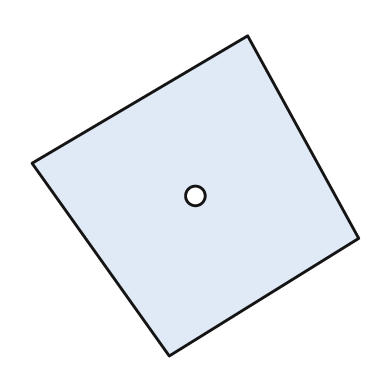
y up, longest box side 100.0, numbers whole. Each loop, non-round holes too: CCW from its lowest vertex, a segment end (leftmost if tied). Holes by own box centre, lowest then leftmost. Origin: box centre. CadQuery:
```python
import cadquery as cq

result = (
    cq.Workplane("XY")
    .moveTo(-8.0, -49.0)
    .lineTo(50.0, -13.0)
    .lineTo(16.0, 49.0)
    .lineTo(-50.0, 10.0)
    .close()
    .moveTo(0.0, 0.0)
    .circle(3.0)
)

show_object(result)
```